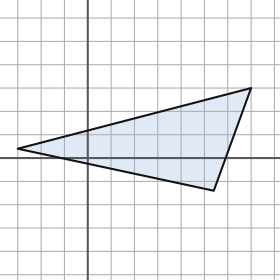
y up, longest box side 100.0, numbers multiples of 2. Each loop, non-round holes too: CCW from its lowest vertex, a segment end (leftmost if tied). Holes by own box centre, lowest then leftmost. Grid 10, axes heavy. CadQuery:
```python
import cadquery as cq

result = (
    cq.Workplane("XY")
    .moveTo(54.0, -14.0)
    .lineTo(70.0, 30.0)
    .lineTo(-30.0, 4.0)
    .close()
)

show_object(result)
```